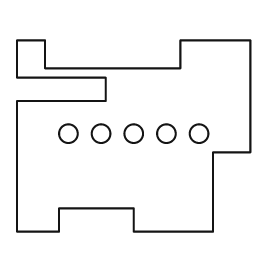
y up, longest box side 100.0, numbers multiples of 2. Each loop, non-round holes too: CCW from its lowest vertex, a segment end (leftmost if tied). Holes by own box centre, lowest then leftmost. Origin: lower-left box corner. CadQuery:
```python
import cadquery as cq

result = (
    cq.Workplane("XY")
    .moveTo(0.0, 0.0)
    .lineTo(18.0, 0.0)
    .lineTo(18.0, 10.0)
    .lineTo(50.0, 10.0)
    .lineTo(50.0, 0.0)
    .lineTo(84.0, 0.0)
    .lineTo(84.0, 34.0)
    .lineTo(100.0, 34.0)
    .lineTo(100.0, 82.0)
    .lineTo(70.0, 82.0)
    .lineTo(70.0, 70.0)
    .lineTo(12.0, 70.0)
    .lineTo(12.0, 82.0)
    .lineTo(0.0, 82.0)
    .lineTo(0.0, 66.0)
    .lineTo(38.0, 66.0)
    .lineTo(38.0, 56.0)
    .lineTo(0.0, 56.0)
    .close()
    .moveTo(22.0, 42.0)
    .circle(4.0)
    .moveTo(36.0, 42.0)
    .circle(4.0)
    .moveTo(50.0, 42.0)
    .circle(4.0)
    .moveTo(64.0, 42.0)
    .circle(4.0)
    .moveTo(78.0, 42.0)
    .circle(4.0)
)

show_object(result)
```